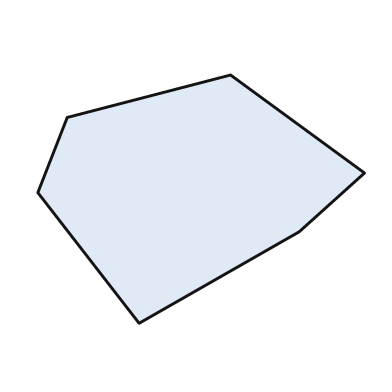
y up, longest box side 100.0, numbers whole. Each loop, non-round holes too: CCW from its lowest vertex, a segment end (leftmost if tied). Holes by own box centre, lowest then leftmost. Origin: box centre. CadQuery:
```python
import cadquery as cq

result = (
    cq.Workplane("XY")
    .moveTo(-19.0, -38.0)
    .lineTo(30.0, -10.0)
    .lineTo(50.0, 8.0)
    .lineTo(9.0, 38.0)
    .lineTo(-41.0, 25.0)
    .lineTo(-50.0, 2.0)
    .close()
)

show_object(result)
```